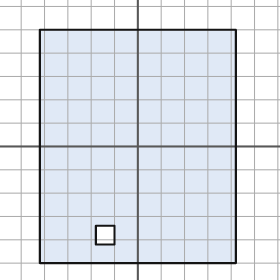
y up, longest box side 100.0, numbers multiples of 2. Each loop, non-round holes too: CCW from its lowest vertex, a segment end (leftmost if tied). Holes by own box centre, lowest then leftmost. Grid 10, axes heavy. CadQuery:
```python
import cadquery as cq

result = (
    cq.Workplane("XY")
    .moveTo(-42.0, -50.0)
    .lineTo(42.0, -50.0)
    .lineTo(42.0, 50.0)
    .lineTo(-42.0, 50.0)
    .close()
    .moveTo(-18.0, -42.0)
    .lineTo(-10.0, -42.0)
    .lineTo(-10.0, -34.0)
    .lineTo(-18.0, -34.0)
    .close()
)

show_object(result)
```